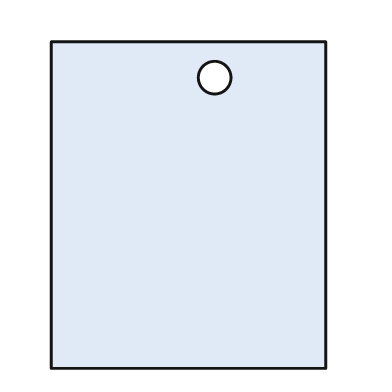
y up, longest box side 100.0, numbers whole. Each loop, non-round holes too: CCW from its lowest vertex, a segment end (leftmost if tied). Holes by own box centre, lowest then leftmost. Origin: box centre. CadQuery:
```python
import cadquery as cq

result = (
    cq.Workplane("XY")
    .moveTo(-42.0, -50.0)
    .lineTo(42.0, -50.0)
    .lineTo(42.0, 50.0)
    .lineTo(-42.0, 50.0)
    .close()
    .moveTo(8.0, 39.0)
    .circle(5.0)
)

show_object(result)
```